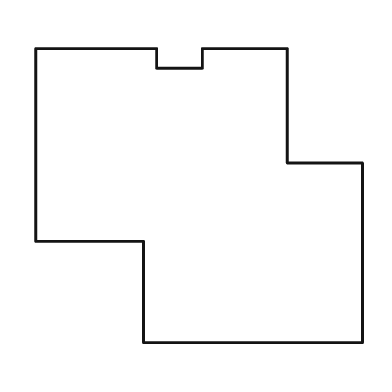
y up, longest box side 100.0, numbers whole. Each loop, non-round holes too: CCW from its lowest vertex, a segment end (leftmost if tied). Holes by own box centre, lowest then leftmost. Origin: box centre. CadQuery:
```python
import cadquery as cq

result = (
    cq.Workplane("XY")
    .moveTo(-17.0, -45.0)
    .lineTo(50.0, -45.0)
    .lineTo(50.0, 10.0)
    .lineTo(27.0, 10.0)
    .lineTo(27.0, 45.0)
    .lineTo(1.0, 45.0)
    .lineTo(1.0, 39.0)
    .lineTo(-13.0, 39.0)
    .lineTo(-13.0, 45.0)
    .lineTo(-50.0, 45.0)
    .lineTo(-50.0, -14.0)
    .lineTo(-17.0, -14.0)
    .close()
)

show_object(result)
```